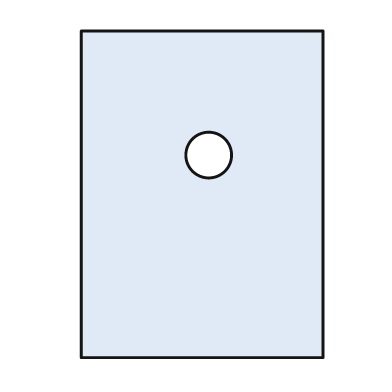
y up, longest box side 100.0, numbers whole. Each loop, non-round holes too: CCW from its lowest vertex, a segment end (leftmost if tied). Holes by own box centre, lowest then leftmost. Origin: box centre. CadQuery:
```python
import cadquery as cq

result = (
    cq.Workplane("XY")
    .moveTo(-37.0, -50.0)
    .lineTo(37.0, -50.0)
    .lineTo(37.0, 50.0)
    .lineTo(-37.0, 50.0)
    .close()
    .moveTo(2.0, 12.0)
    .circle(7.0)
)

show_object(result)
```